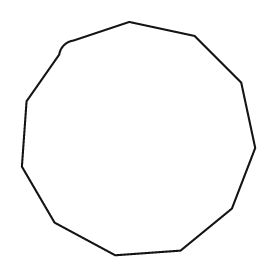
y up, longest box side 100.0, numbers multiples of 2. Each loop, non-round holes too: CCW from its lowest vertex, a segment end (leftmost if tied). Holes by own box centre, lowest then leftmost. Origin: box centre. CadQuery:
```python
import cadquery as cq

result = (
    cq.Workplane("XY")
    .moveTo(-10.0, -50.0)
    .lineTo(18.0, -48.0)
    .lineTo(40.0, -30.0)
    .lineTo(50.0, -4.0)
    .lineTo(44.0, 24.0)
    .lineTo(24.0, 44.0)
    .lineTo(-4.0, 50.0)
    .lineTo(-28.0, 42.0)
    .threePointArc((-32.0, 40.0), (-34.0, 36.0))
    .lineTo(-48.0, 16.0)
    .lineTo(-50.0, -12.0)
    .lineTo(-36.0, -36.0)
    .close()
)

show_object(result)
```